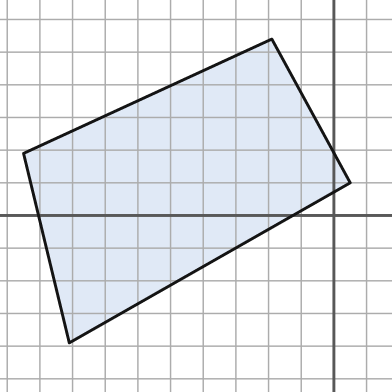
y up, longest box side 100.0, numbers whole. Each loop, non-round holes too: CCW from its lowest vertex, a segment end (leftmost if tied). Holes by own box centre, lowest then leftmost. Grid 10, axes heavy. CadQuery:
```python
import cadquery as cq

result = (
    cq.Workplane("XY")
    .moveTo(-81.0, -39.0)
    .lineTo(5.0, 10.0)
    .lineTo(-19.0, 54.0)
    .lineTo(-95.0, 19.0)
    .close()
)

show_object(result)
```